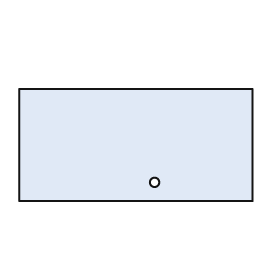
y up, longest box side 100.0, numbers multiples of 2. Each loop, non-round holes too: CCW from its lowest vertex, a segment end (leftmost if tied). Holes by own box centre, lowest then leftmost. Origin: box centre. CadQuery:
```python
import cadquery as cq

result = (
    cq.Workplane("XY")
    .moveTo(-50.0, -24.0)
    .lineTo(50.0, -24.0)
    .lineTo(50.0, 24.0)
    .lineTo(-50.0, 24.0)
    .close()
    .moveTo(8.0, -16.0)
    .circle(2.0)
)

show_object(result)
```